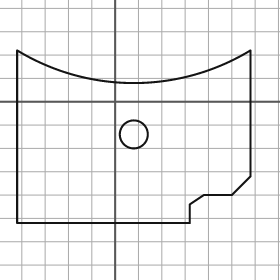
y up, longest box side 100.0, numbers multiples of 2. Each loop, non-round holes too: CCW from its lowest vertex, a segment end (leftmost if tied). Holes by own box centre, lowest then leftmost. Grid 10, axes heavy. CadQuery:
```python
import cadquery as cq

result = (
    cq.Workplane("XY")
    .moveTo(-42.0, -52.0)
    .lineTo(32.0, -52.0)
    .lineTo(32.0, -44.0)
    .lineTo(38.0, -40.0)
    .lineTo(50.0, -40.0)
    .lineTo(58.0, -32.0)
    .lineTo(58.0, 22.0)
    .threePointArc((8.0, 8.0), (-42.0, 22.0))
    .close()
    .moveTo(8.0, -14.0)
    .circle(6.0)
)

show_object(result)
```